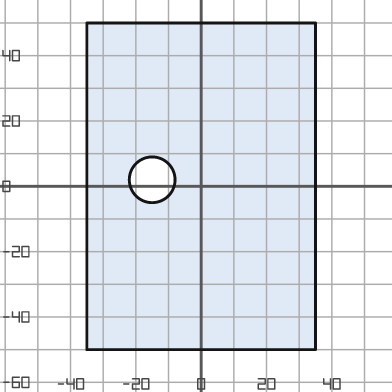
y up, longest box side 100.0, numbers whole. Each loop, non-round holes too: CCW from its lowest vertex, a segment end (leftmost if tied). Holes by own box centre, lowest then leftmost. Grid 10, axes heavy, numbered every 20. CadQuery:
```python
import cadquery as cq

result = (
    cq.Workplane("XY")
    .moveTo(-35.0, -50.0)
    .lineTo(35.0, -50.0)
    .lineTo(35.0, 50.0)
    .lineTo(-35.0, 50.0)
    .close()
    .moveTo(-15.0, 2.0)
    .circle(7.0)
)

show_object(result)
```